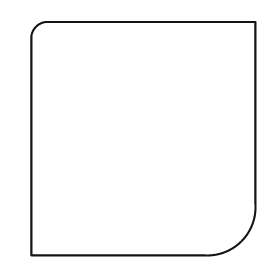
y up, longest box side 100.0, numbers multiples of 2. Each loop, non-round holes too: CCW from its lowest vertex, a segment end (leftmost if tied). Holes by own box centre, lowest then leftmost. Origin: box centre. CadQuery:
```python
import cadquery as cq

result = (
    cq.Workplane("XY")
    .moveTo(-48.0, -50.0)
    .lineTo(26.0, -50.0)
    .threePointArc((42.0, -44.0), (48.0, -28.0))
    .lineTo(48.0, 50.0)
    .lineTo(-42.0, 50.0)
    .threePointArc((-46.0, 48.0), (-48.0, 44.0))
    .close()
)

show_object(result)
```